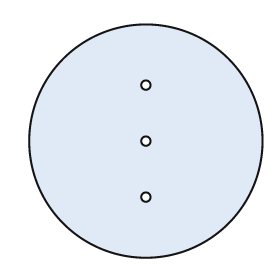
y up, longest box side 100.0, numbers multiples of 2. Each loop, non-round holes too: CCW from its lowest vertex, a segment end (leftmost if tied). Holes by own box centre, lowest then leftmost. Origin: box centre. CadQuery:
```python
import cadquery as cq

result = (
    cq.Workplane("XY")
    .moveTo(0.0, 0.0)
    .circle(50.0)
    .moveTo(0.0, -24.0)
    .circle(2.0)
    .moveTo(0.0, 0.0)
    .circle(2.0)
    .moveTo(0.0, 24.0)
    .circle(2.0)
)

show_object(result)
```